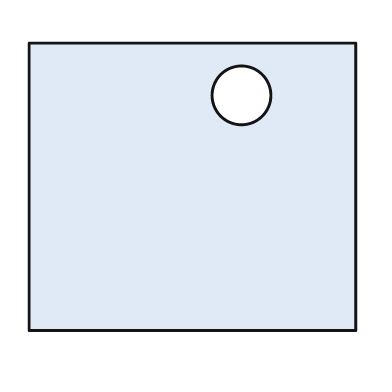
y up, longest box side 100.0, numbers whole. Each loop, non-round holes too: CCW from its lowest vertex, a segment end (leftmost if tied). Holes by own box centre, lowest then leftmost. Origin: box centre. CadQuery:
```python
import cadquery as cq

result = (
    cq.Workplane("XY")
    .moveTo(-50.0, -44.0)
    .lineTo(50.0, -44.0)
    .lineTo(50.0, 44.0)
    .lineTo(-50.0, 44.0)
    .close()
    .moveTo(15.0, 28.0)
    .circle(9.0)
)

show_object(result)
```